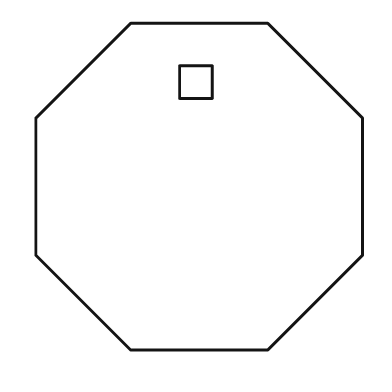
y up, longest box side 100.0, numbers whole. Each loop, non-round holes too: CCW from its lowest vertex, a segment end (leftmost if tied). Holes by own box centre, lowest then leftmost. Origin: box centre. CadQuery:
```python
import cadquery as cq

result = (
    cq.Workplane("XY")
    .moveTo(-21.0, -50.0)
    .lineTo(21.0, -50.0)
    .lineTo(50.0, -21.0)
    .lineTo(50.0, 21.0)
    .lineTo(21.0, 50.0)
    .lineTo(-21.0, 50.0)
    .lineTo(-50.0, 21.0)
    .lineTo(-50.0, -21.0)
    .close()
    .moveTo(-6.0, 27.0)
    .lineTo(4.0, 27.0)
    .lineTo(4.0, 37.0)
    .lineTo(-6.0, 37.0)
    .close()
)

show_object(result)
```